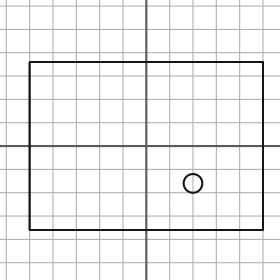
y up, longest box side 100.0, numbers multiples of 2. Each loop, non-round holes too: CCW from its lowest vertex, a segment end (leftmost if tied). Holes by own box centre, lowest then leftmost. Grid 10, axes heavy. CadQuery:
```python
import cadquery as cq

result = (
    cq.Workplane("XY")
    .moveTo(-50.0, -36.0)
    .lineTo(50.0, -36.0)
    .lineTo(50.0, 36.0)
    .lineTo(-50.0, 36.0)
    .close()
    .moveTo(20.0, -16.0)
    .circle(4.0)
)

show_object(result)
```